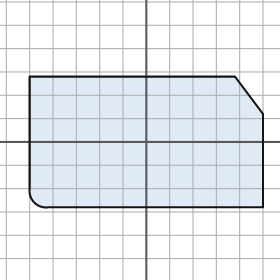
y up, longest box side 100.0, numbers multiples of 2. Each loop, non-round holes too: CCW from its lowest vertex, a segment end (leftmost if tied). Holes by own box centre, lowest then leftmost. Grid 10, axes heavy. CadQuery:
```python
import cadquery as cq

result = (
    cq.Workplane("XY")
    .moveTo(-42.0, -28.0)
    .lineTo(50.0, -28.0)
    .lineTo(50.0, 12.0)
    .lineTo(38.0, 28.0)
    .lineTo(-50.0, 28.0)
    .lineTo(-50.0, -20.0)
    .threePointArc((-48.0, -26.0), (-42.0, -28.0))
    .close()
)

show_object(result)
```